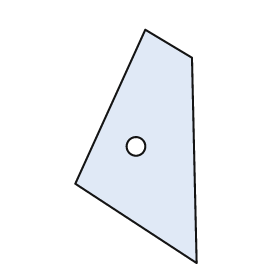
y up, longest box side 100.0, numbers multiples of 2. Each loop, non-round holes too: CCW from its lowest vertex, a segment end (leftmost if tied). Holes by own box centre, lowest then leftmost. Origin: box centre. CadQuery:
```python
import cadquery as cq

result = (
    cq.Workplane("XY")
    .moveTo(26.0, -50.0)
    .lineTo(24.0, 38.0)
    .lineTo(4.0, 50.0)
    .lineTo(-26.0, -16.0)
    .close()
    .moveTo(0.0, 0.0)
    .circle(4.0)
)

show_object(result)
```